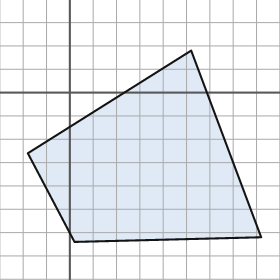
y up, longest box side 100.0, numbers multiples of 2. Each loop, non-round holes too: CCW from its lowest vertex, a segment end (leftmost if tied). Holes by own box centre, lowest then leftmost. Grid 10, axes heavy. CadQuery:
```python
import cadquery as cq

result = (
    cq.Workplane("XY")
    .moveTo(2.0, -64.0)
    .lineTo(82.0, -62.0)
    .lineTo(52.0, 18.0)
    .lineTo(-18.0, -26.0)
    .close()
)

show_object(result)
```